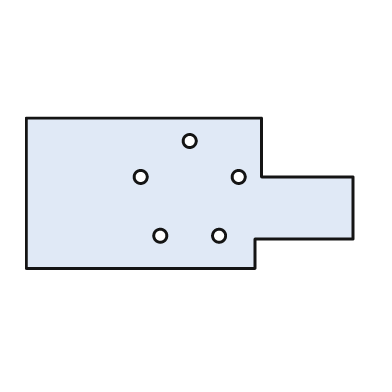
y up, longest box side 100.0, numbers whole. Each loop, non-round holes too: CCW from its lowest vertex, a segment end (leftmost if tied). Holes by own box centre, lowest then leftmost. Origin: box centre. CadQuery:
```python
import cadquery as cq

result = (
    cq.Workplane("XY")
    .moveTo(-50.0, -23.0)
    .lineTo(20.0, -23.0)
    .lineTo(20.0, -14.0)
    .lineTo(50.0, -14.0)
    .lineTo(50.0, 5.0)
    .lineTo(22.0, 5.0)
    .lineTo(22.0, 23.0)
    .lineTo(-50.0, 23.0)
    .close()
    .moveTo(-9.0, -13.0)
    .circle(2.0)
    .moveTo(9.0, -13.0)
    .circle(2.0)
    .moveTo(-15.0, 5.0)
    .circle(2.0)
    .moveTo(15.0, 5.0)
    .circle(2.0)
    .moveTo(0.0, 16.0)
    .circle(2.0)
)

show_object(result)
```